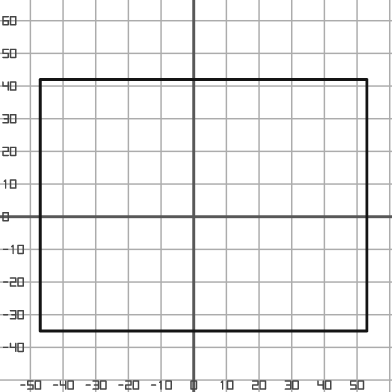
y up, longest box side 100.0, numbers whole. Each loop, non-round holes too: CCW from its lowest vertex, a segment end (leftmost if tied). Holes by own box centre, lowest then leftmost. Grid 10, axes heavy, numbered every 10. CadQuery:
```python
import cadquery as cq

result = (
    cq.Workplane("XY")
    .moveTo(-47.0, -35.0)
    .lineTo(53.0, -35.0)
    .lineTo(53.0, 42.0)
    .lineTo(-47.0, 42.0)
    .close()
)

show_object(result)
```